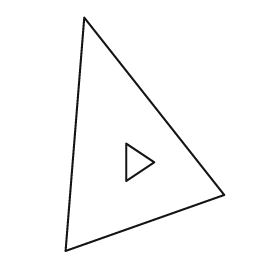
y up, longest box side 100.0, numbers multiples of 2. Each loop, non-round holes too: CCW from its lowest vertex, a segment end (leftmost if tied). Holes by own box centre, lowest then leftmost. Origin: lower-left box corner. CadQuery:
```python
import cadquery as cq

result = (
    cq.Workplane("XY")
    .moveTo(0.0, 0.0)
    .lineTo(68.0, 24.0)
    .lineTo(8.0, 100.0)
    .close()
    .moveTo(26.0, 30.0)
    .lineTo(38.0, 38.0)
    .lineTo(26.0, 46.0)
    .close()
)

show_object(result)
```